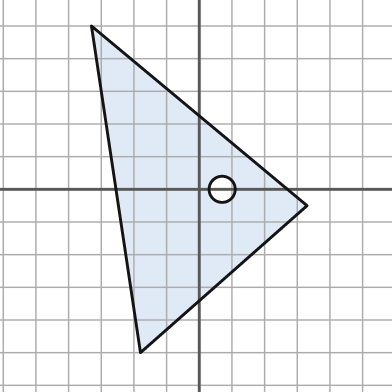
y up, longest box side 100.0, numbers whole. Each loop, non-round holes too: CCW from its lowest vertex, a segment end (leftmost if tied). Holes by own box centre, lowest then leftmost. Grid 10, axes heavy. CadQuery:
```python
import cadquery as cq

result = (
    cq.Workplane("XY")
    .moveTo(-18.0, -50.0)
    .lineTo(33.0, -5.0)
    .lineTo(-33.0, 50.0)
    .close()
    .moveTo(7.0, 0.0)
    .circle(4.0)
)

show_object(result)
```